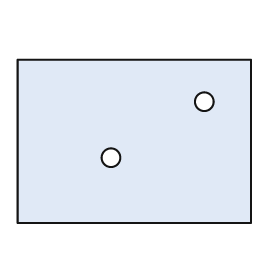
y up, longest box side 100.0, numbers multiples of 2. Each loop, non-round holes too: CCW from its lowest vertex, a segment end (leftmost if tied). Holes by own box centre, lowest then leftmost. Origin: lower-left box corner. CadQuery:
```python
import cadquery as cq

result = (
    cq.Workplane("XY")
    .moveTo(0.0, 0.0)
    .lineTo(100.0, 0.0)
    .lineTo(100.0, 70.0)
    .lineTo(0.0, 70.0)
    .close()
    .moveTo(40.0, 28.0)
    .circle(4.0)
    .moveTo(80.0, 52.0)
    .circle(4.0)
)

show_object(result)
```